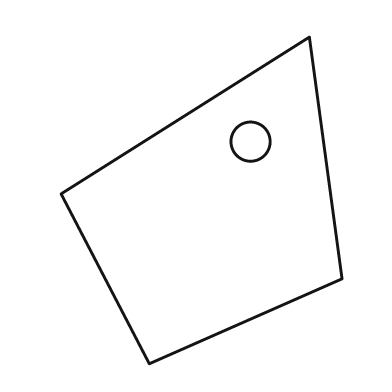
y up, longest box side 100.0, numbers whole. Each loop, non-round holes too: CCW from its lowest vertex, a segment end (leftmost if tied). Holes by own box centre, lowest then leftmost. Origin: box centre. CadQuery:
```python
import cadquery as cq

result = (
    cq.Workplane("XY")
    .moveTo(-16.0, -50.0)
    .lineTo(43.0, -24.0)
    .lineTo(33.0, 50.0)
    .lineTo(-43.0, 2.0)
    .close()
    .moveTo(15.0, 18.0)
    .circle(6.0)
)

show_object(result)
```